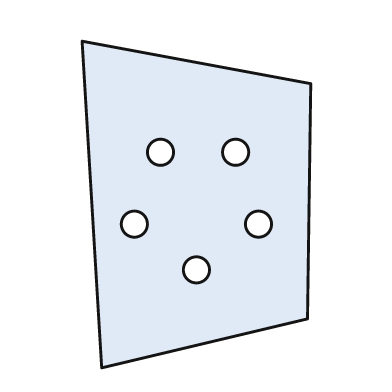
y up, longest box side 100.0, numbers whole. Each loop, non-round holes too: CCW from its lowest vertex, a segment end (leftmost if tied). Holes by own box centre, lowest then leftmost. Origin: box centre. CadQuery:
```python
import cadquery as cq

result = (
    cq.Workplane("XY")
    .moveTo(-29.0, -50.0)
    .lineTo(34.0, -35.0)
    .lineTo(35.0, 37.0)
    .lineTo(-35.0, 50.0)
    .close()
    .moveTo(0.0, -20.0)
    .circle(4.0)
    .moveTo(-19.0, -6.0)
    .circle(4.0)
    .moveTo(19.0, -6.0)
    .circle(4.0)
    .moveTo(-11.0, 16.0)
    .circle(4.0)
    .moveTo(12.0, 16.0)
    .circle(4.0)
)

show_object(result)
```